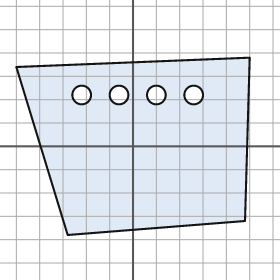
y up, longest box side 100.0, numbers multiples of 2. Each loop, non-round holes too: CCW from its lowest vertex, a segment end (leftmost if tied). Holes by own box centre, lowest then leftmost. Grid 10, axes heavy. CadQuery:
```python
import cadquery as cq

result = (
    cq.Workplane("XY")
    .moveTo(-28.0, -38.0)
    .lineTo(48.0, -32.0)
    .lineTo(50.0, 38.0)
    .lineTo(-50.0, 34.0)
    .close()
    .moveTo(-22.0, 22.0)
    .circle(4.0)
    .moveTo(-6.0, 22.0)
    .circle(4.0)
    .moveTo(10.0, 22.0)
    .circle(4.0)
    .moveTo(26.0, 22.0)
    .circle(4.0)
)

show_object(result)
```